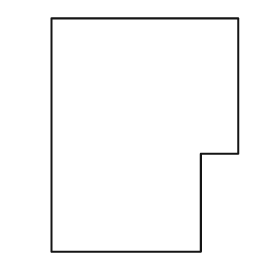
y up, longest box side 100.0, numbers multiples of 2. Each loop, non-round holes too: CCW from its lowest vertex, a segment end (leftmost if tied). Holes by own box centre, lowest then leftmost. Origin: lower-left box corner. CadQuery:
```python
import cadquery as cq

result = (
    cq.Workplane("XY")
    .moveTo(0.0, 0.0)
    .lineTo(64.0, 0.0)
    .lineTo(64.0, 42.0)
    .lineTo(80.0, 42.0)
    .lineTo(80.0, 100.0)
    .lineTo(0.0, 100.0)
    .close()
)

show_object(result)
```